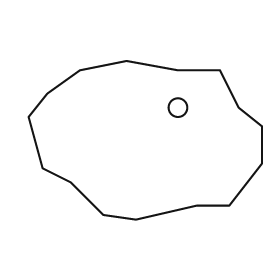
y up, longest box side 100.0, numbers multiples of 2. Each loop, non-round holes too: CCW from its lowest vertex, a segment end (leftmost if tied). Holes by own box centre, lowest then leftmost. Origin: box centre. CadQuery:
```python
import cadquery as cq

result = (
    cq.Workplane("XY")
    .moveTo(-4.0, -34.0)
    .lineTo(22.0, -28.0)
    .lineTo(36.0, -28.0)
    .lineTo(50.0, -10.0)
    .lineTo(50.0, 6.0)
    .lineTo(40.0, 14.0)
    .lineTo(32.0, 30.0)
    .lineTo(14.0, 30.0)
    .lineTo(-8.0, 34.0)
    .lineTo(-28.0, 30.0)
    .lineTo(-42.0, 20.0)
    .lineTo(-50.0, 10.0)
    .lineTo(-44.0, -12.0)
    .lineTo(-32.0, -18.0)
    .lineTo(-18.0, -32.0)
    .close()
    .moveTo(14.0, 14.0)
    .circle(4.0)
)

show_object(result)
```